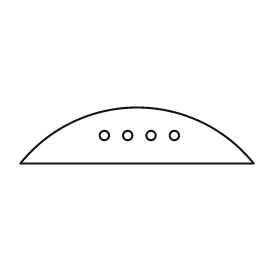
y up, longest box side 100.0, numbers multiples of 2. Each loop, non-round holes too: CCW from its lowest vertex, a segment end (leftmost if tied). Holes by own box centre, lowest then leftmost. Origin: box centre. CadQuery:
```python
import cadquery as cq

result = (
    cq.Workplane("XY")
    .moveTo(-50.0, -12.0)
    .lineTo(50.0, -12.0)
    .threePointArc((0.0, 12.0), (-50.0, -12.0))
    .close()
    .moveTo(-14.0, 0.0)
    .circle(2.0)
    .moveTo(-4.0, 0.0)
    .circle(2.0)
    .moveTo(6.0, 0.0)
    .circle(2.0)
    .moveTo(16.0, 0.0)
    .circle(2.0)
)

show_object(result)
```